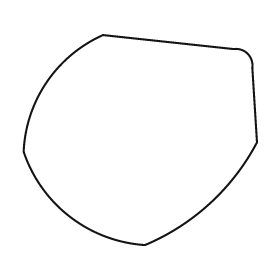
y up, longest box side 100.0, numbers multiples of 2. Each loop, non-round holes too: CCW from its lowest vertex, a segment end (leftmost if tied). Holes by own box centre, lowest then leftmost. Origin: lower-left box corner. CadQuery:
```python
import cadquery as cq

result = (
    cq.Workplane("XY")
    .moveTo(52.0, 0.0)
    .threePointArc((80.0, 18.0), (100.0, 44.0))
    .lineTo(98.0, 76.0)
    .threePointArc((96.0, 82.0), (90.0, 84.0))
    .lineTo(34.0, 90.0)
    .threePointArc((10.0, 70.0), (0.0, 40.0))
    .threePointArc((20.0, 12.0), (52.0, 0.0))
    .close()
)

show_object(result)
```